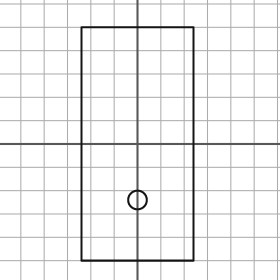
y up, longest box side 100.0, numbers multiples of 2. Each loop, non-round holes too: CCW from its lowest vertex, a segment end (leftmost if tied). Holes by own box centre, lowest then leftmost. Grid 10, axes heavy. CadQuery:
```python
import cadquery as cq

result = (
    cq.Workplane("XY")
    .moveTo(-24.0, -50.0)
    .lineTo(24.0, -50.0)
    .lineTo(24.0, 50.0)
    .lineTo(-24.0, 50.0)
    .close()
    .moveTo(0.0, -24.0)
    .circle(4.0)
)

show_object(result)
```